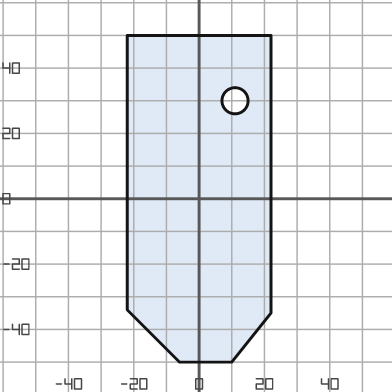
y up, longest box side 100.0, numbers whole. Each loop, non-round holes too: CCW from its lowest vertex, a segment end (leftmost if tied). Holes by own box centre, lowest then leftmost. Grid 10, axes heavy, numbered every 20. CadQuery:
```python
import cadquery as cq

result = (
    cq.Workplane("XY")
    .moveTo(-6.0, -50.0)
    .lineTo(10.0, -50.0)
    .lineTo(22.0, -35.0)
    .lineTo(22.0, 50.0)
    .lineTo(-22.0, 50.0)
    .lineTo(-22.0, -34.0)
    .close()
    .moveTo(11.0, 30.0)
    .circle(4.0)
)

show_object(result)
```